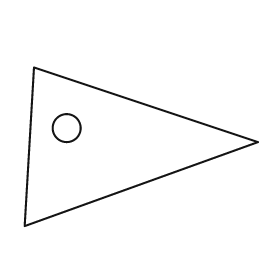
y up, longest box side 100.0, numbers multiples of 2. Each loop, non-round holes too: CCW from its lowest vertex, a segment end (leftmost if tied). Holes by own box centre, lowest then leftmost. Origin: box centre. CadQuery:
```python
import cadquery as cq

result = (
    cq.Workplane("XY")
    .moveTo(-50.0, -34.0)
    .lineTo(50.0, 2.0)
    .lineTo(-46.0, 34.0)
    .close()
    .moveTo(-32.0, 8.0)
    .circle(6.0)
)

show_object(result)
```